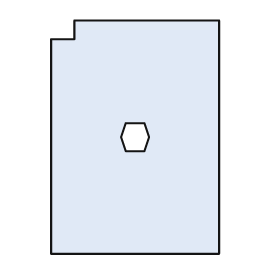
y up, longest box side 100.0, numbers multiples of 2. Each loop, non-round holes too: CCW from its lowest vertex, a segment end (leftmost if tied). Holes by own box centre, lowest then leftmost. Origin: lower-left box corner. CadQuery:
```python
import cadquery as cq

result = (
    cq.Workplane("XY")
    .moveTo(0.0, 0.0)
    .lineTo(72.0, 0.0)
    .lineTo(72.0, 100.0)
    .lineTo(10.0, 100.0)
    .lineTo(10.0, 92.0)
    .lineTo(0.0, 92.0)
    .close()
    .moveTo(32.0, 44.0)
    .lineTo(40.0, 44.0)
    .lineTo(42.0, 50.0)
    .lineTo(40.0, 56.0)
    .lineTo(32.0, 56.0)
    .lineTo(30.0, 50.0)
    .close()
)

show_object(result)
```